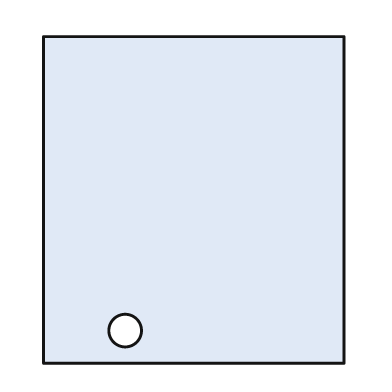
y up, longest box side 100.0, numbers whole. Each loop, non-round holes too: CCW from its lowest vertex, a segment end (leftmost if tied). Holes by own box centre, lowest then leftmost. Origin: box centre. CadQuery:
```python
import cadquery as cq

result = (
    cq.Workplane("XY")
    .moveTo(-46.0, -50.0)
    .lineTo(46.0, -50.0)
    .lineTo(46.0, 50.0)
    .lineTo(-46.0, 50.0)
    .close()
    .moveTo(-21.0, -40.0)
    .circle(5.0)
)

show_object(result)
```